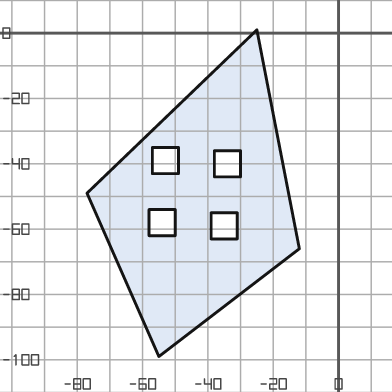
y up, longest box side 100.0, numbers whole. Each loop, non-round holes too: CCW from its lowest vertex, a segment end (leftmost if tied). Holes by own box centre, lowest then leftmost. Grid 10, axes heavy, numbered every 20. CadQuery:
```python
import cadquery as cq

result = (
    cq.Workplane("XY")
    .moveTo(-55.0, -99.0)
    .lineTo(-12.0, -66.0)
    .lineTo(-25.0, 1.0)
    .lineTo(-77.0, -49.0)
    .close()
    .moveTo(-39.0, -63.0)
    .lineTo(-31.0, -63.0)
    .lineTo(-31.0, -55.0)
    .lineTo(-39.0, -55.0)
    .close()
    .moveTo(-58.0, -62.0)
    .lineTo(-50.0, -62.0)
    .lineTo(-50.0, -54.0)
    .lineTo(-58.0, -54.0)
    .close()
    .moveTo(-38.0, -44.0)
    .lineTo(-30.0, -44.0)
    .lineTo(-30.0, -36.0)
    .lineTo(-38.0, -36.0)
    .close()
    .moveTo(-57.0, -43.0)
    .lineTo(-49.0, -43.0)
    .lineTo(-49.0, -35.0)
    .lineTo(-57.0, -35.0)
    .close()
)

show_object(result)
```